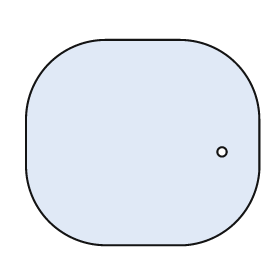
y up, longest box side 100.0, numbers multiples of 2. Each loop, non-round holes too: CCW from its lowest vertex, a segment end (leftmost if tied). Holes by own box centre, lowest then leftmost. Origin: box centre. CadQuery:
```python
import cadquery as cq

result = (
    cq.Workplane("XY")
    .moveTo(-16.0, -44.0)
    .lineTo(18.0, -44.0)
    .threePointArc((40.0, -34.0), (50.0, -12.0))
    .lineTo(50.0, 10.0)
    .threePointArc((40.0, 34.0), (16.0, 44.0))
    .lineTo(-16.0, 44.0)
    .threePointArc((-40.0, 34.0), (-50.0, 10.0))
    .lineTo(-50.0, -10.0)
    .threePointArc((-40.0, -34.0), (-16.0, -44.0))
    .close()
    .moveTo(34.0, -4.0)
    .circle(2.0)
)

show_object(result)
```